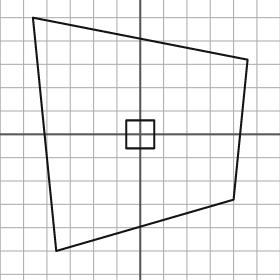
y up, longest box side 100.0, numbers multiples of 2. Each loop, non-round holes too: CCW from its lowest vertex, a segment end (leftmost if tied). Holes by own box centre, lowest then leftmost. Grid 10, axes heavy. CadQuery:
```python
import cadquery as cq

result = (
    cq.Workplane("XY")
    .moveTo(-36.0, -50.0)
    .lineTo(40.0, -28.0)
    .lineTo(46.0, 32.0)
    .lineTo(-46.0, 50.0)
    .close()
    .moveTo(-6.0, -6.0)
    .lineTo(6.0, -6.0)
    .lineTo(6.0, 6.0)
    .lineTo(-6.0, 6.0)
    .close()
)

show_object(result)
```